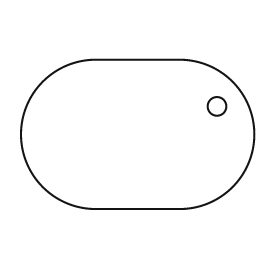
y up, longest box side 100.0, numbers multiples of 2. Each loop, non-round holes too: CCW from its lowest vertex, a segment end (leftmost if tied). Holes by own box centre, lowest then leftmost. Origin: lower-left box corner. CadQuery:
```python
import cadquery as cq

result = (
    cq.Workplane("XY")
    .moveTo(32.0, 0.0)
    .lineTo(68.0, 0.0)
    .threePointArc((100.0, 32.0), (68.0, 64.0))
    .lineTo(32.0, 64.0)
    .threePointArc((0.0, 32.0), (32.0, 0.0))
    .close()
    .moveTo(84.0, 44.0)
    .circle(4.0)
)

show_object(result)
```